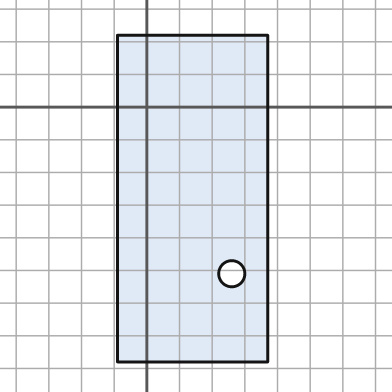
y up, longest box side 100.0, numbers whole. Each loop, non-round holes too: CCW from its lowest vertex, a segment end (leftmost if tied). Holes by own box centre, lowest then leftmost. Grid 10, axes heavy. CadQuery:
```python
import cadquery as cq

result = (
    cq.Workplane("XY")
    .moveTo(-9.0, -78.0)
    .lineTo(37.0, -78.0)
    .lineTo(37.0, 22.0)
    .lineTo(-9.0, 22.0)
    .close()
    .moveTo(26.0, -51.0)
    .circle(4.0)
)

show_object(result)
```